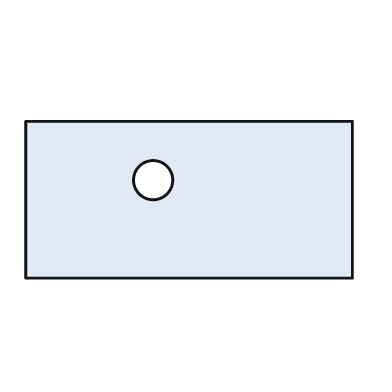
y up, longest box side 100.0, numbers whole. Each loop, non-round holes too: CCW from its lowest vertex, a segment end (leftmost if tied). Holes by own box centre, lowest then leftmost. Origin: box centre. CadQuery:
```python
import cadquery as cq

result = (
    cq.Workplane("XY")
    .moveTo(-50.0, -24.0)
    .lineTo(50.0, -24.0)
    .lineTo(50.0, 24.0)
    .lineTo(-50.0, 24.0)
    .close()
    .moveTo(-11.0, 6.0)
    .circle(6.0)
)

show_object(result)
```